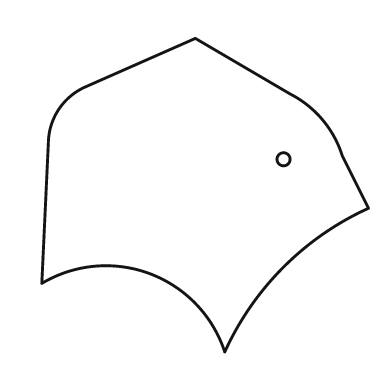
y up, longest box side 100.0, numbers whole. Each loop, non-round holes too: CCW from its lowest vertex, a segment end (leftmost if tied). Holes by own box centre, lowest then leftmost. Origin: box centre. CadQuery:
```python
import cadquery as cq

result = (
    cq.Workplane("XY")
    .moveTo(6.0, -48.0)
    .threePointArc((24.0, -22.0), (50.0, -4.0))
    .lineTo(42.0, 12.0)
    .threePointArc((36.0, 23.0), (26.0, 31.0))
    .lineTo(-3.0, 48.0)
    .lineTo(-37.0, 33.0)
    .threePointArc((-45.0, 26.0), (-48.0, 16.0))
    .lineTo(-50.0, -27.0)
    .threePointArc((-17.0, -24.0), (6.0, -48.0))
    .close()
    .moveTo(24.0, 11.0)
    .circle(2.0)
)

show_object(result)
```